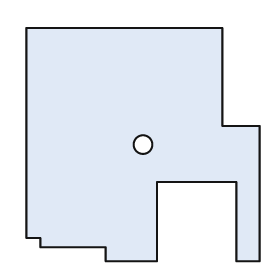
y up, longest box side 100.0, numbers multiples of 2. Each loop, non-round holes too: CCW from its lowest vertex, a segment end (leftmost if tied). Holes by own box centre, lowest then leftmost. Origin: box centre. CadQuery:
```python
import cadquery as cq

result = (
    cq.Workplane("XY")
    .moveTo(-16.0, -50.0)
    .lineTo(6.0, -50.0)
    .lineTo(6.0, -16.0)
    .lineTo(40.0, -16.0)
    .lineTo(40.0, -50.0)
    .lineTo(50.0, -50.0)
    .lineTo(50.0, 8.0)
    .lineTo(34.0, 8.0)
    .lineTo(34.0, 50.0)
    .lineTo(-50.0, 50.0)
    .lineTo(-50.0, -40.0)
    .lineTo(-44.0, -40.0)
    .lineTo(-44.0, -44.0)
    .lineTo(-16.0, -44.0)
    .close()
    .moveTo(0.0, 0.0)
    .circle(4.0)
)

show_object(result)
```